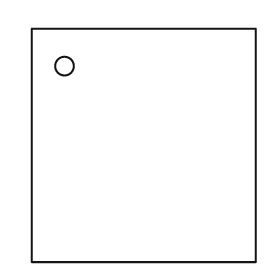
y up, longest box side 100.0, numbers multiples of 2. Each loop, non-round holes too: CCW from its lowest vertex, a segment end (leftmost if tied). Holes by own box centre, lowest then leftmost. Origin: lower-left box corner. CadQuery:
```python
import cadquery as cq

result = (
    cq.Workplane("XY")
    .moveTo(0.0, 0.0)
    .lineTo(96.0, 0.0)
    .lineTo(96.0, 100.0)
    .lineTo(0.0, 100.0)
    .close()
    .moveTo(14.0, 84.0)
    .circle(4.0)
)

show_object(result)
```